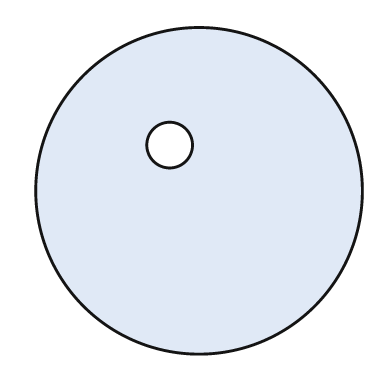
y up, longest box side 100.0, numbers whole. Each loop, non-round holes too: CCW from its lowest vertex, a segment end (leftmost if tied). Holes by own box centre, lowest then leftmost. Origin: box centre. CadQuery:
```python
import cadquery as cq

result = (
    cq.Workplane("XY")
    .moveTo(0.0, 0.0)
    .circle(50.0)
    .moveTo(-9.0, 14.0)
    .circle(7.0)
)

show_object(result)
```